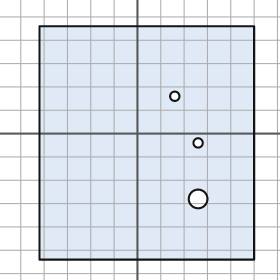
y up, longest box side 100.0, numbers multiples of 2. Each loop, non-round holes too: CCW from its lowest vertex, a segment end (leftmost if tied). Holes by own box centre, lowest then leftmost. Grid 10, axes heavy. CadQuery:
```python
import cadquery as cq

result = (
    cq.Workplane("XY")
    .moveTo(-42.0, -54.0)
    .lineTo(50.0, -54.0)
    .lineTo(50.0, 46.0)
    .lineTo(-42.0, 46.0)
    .close()
    .moveTo(26.0, -28.0)
    .circle(4.0)
    .moveTo(26.0, -4.0)
    .circle(2.0)
    .moveTo(16.0, 16.0)
    .circle(2.0)
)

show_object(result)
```